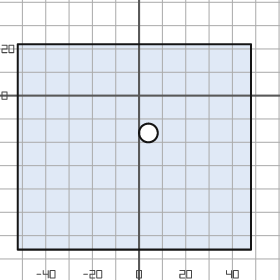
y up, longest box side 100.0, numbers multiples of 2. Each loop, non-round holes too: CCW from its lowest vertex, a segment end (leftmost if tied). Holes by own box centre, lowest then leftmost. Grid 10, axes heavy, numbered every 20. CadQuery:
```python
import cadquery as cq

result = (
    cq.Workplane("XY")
    .moveTo(-52.0, -66.0)
    .lineTo(48.0, -66.0)
    .lineTo(48.0, 22.0)
    .lineTo(-52.0, 22.0)
    .close()
    .moveTo(4.0, -16.0)
    .circle(4.0)
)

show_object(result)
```